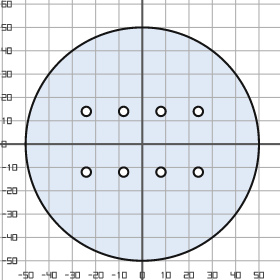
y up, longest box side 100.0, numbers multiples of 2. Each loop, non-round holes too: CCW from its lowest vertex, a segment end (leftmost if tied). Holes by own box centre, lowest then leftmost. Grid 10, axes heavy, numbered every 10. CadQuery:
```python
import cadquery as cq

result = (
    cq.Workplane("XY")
    .moveTo(0.0, 0.0)
    .circle(50.0)
    .moveTo(-24.0, -12.0)
    .circle(2.0)
    .moveTo(-8.0, -12.0)
    .circle(2.0)
    .moveTo(8.0, -12.0)
    .circle(2.0)
    .moveTo(24.0, -12.0)
    .circle(2.0)
    .moveTo(-24.0, 14.0)
    .circle(2.0)
    .moveTo(-8.0, 14.0)
    .circle(2.0)
    .moveTo(8.0, 14.0)
    .circle(2.0)
    .moveTo(24.0, 14.0)
    .circle(2.0)
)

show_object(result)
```